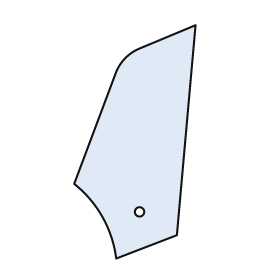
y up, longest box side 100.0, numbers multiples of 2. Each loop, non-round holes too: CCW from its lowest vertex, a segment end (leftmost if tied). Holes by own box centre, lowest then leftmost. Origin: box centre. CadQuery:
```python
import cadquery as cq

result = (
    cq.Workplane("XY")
    .moveTo(-8.0, -50.0)
    .lineTo(18.0, -40.0)
    .lineTo(26.0, 50.0)
    .lineTo(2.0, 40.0)
    .threePointArc((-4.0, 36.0), (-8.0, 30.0))
    .lineTo(-26.0, -18.0)
    .threePointArc((-14.0, -32.0), (-8.0, -50.0))
    .close()
    .moveTo(2.0, -30.0)
    .circle(2.0)
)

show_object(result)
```